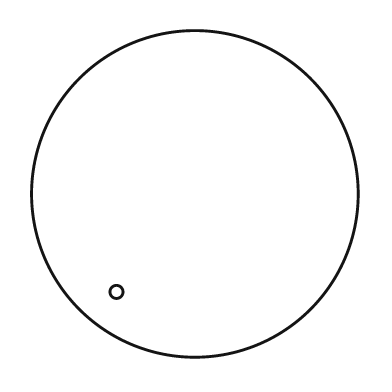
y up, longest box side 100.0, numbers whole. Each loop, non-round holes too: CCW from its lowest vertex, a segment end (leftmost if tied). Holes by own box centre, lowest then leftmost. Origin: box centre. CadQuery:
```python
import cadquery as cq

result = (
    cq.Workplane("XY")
    .moveTo(0.0, 0.0)
    .circle(50.0)
    .moveTo(-24.0, -30.0)
    .circle(2.0)
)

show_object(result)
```